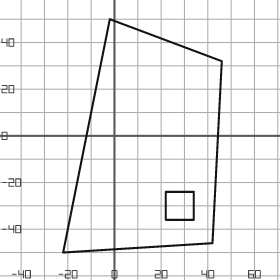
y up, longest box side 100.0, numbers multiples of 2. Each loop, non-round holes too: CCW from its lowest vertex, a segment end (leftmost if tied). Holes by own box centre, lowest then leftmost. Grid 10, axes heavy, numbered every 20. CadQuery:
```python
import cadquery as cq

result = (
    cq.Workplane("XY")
    .moveTo(-22.0, -50.0)
    .lineTo(42.0, -46.0)
    .lineTo(46.0, 32.0)
    .lineTo(-2.0, 50.0)
    .close()
    .moveTo(22.0, -36.0)
    .lineTo(34.0, -36.0)
    .lineTo(34.0, -24.0)
    .lineTo(22.0, -24.0)
    .close()
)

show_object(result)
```